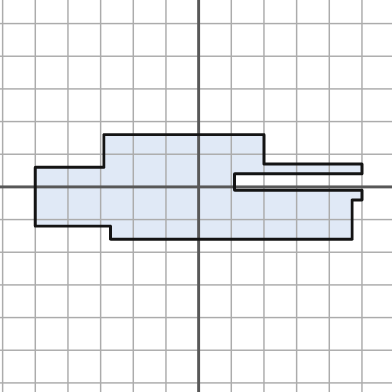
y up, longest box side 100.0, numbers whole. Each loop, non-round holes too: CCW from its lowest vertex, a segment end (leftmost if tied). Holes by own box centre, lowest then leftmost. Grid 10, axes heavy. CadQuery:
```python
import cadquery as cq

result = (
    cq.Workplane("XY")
    .moveTo(-27.0, -16.0)
    .lineTo(47.0, -16.0)
    .lineTo(47.0, -4.0)
    .lineTo(50.0, -4.0)
    .lineTo(50.0, -1.0)
    .lineTo(11.0, -1.0)
    .lineTo(11.0, 4.0)
    .lineTo(50.0, 4.0)
    .lineTo(50.0, 7.0)
    .lineTo(20.0, 7.0)
    .lineTo(20.0, 16.0)
    .lineTo(-29.0, 16.0)
    .lineTo(-29.0, 6.0)
    .lineTo(-50.0, 6.0)
    .lineTo(-50.0, -12.0)
    .lineTo(-27.0, -12.0)
    .close()
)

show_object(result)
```